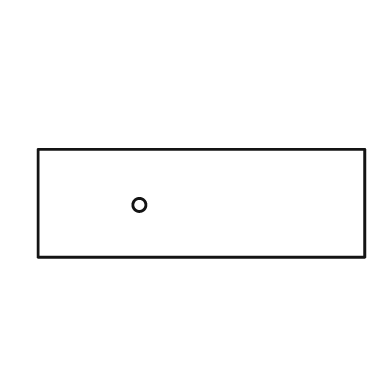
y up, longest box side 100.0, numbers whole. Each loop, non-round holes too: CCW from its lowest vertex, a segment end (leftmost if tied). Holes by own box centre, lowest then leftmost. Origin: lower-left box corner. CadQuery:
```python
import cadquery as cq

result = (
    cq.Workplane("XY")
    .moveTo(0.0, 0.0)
    .lineTo(100.0, 0.0)
    .lineTo(100.0, 33.0)
    .lineTo(0.0, 33.0)
    .close()
    .moveTo(31.0, 16.0)
    .circle(2.0)
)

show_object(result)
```